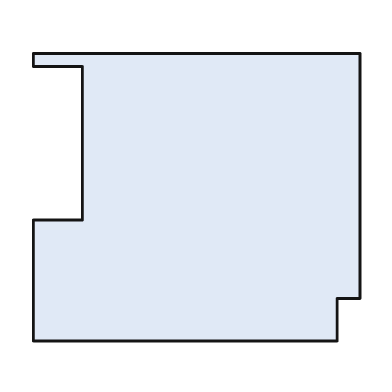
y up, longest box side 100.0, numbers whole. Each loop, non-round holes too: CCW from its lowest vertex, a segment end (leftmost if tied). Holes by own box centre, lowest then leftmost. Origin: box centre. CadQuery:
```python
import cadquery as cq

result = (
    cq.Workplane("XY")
    .moveTo(-50.0, -44.0)
    .lineTo(43.0, -44.0)
    .lineTo(43.0, -31.0)
    .lineTo(50.0, -31.0)
    .lineTo(50.0, 44.0)
    .lineTo(-50.0, 44.0)
    .lineTo(-50.0, 40.0)
    .lineTo(-35.0, 40.0)
    .lineTo(-35.0, -7.0)
    .lineTo(-50.0, -7.0)
    .close()
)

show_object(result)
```